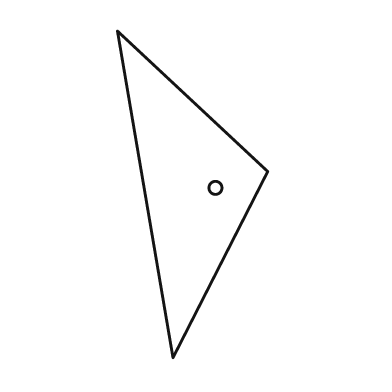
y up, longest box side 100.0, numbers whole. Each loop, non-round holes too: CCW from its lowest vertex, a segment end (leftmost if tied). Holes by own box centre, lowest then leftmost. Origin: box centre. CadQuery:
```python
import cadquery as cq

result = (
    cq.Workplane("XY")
    .moveTo(-6.0, -50.0)
    .lineTo(23.0, 7.0)
    .lineTo(-23.0, 50.0)
    .close()
    .moveTo(7.0, 2.0)
    .circle(2.0)
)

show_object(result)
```